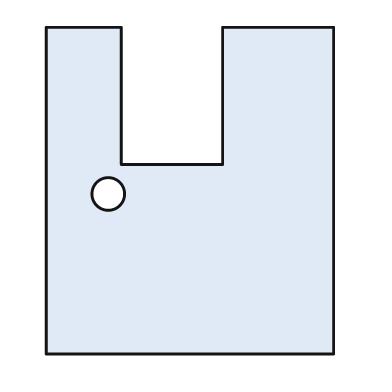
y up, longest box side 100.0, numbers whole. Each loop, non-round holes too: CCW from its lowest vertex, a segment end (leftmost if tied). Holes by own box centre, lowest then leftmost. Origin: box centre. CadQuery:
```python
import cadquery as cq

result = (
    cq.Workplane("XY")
    .moveTo(-44.0, -50.0)
    .lineTo(44.0, -50.0)
    .lineTo(44.0, 50.0)
    .lineTo(10.0, 50.0)
    .lineTo(10.0, 8.0)
    .lineTo(-21.0, 8.0)
    .lineTo(-21.0, 50.0)
    .lineTo(-44.0, 50.0)
    .close()
    .moveTo(-25.0, -1.0)
    .circle(5.0)
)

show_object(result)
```